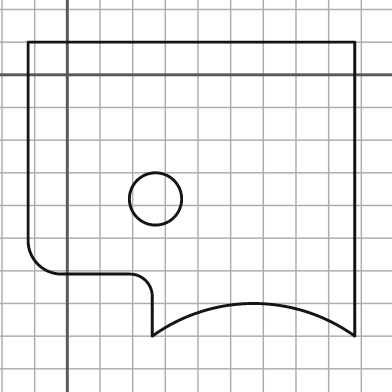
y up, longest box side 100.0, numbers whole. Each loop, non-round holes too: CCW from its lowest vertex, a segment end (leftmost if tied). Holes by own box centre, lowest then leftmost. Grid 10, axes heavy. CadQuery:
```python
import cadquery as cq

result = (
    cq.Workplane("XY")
    .moveTo(26.0, -80.0)
    .threePointArc((57.0, -70.0), (88.0, -80.0))
    .lineTo(88.0, 10.0)
    .lineTo(-12.0, 10.0)
    .lineTo(-12.0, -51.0)
    .threePointArc((-9.0, -58.0), (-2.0, -61.0))
    .lineTo(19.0, -61.0)
    .threePointArc((24.0, -63.0), (26.0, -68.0))
    .close()
    .moveTo(27.0, -38.0)
    .circle(8.0)
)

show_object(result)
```